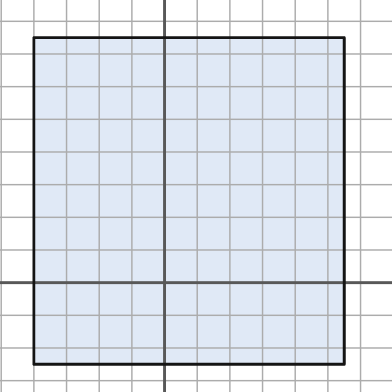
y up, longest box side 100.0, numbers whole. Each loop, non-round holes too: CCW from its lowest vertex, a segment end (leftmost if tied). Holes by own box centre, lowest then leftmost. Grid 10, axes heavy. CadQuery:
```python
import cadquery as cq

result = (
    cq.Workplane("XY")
    .moveTo(-40.0, -25.0)
    .lineTo(55.0, -25.0)
    .lineTo(55.0, 75.0)
    .lineTo(-40.0, 75.0)
    .close()
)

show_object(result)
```